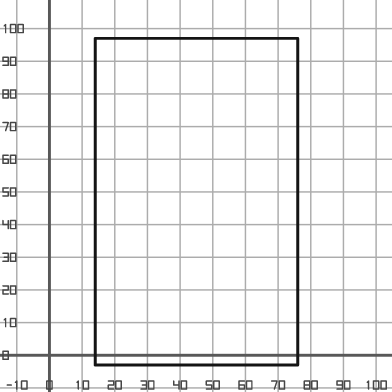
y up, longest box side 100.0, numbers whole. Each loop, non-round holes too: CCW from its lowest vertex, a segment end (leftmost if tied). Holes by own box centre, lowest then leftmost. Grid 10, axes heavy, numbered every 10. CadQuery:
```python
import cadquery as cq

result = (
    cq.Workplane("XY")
    .moveTo(14.0, -3.0)
    .lineTo(76.0, -3.0)
    .lineTo(76.0, 97.0)
    .lineTo(14.0, 97.0)
    .close()
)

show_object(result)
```